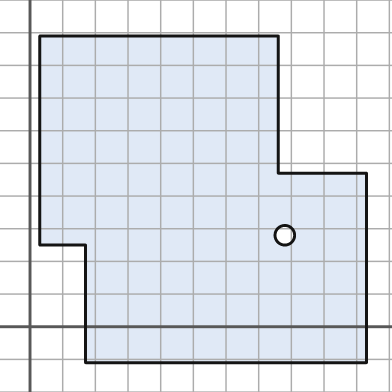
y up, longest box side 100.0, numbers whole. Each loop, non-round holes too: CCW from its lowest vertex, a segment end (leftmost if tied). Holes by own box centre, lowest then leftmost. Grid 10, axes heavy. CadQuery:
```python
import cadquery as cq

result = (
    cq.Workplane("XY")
    .moveTo(17.0, -11.0)
    .lineTo(103.0, -11.0)
    .lineTo(103.0, 47.0)
    .lineTo(76.0, 47.0)
    .lineTo(76.0, 89.0)
    .lineTo(3.0, 89.0)
    .lineTo(3.0, 25.0)
    .lineTo(17.0, 25.0)
    .close()
    .moveTo(78.0, 28.0)
    .circle(3.0)
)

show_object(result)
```